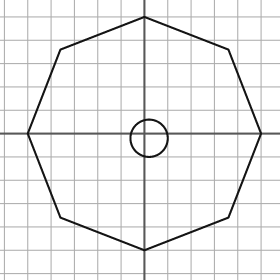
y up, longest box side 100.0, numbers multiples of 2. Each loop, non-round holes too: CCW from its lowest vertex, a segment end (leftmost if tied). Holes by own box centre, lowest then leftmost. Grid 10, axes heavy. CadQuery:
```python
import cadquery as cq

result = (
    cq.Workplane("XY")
    .moveTo(0.0, -50.0)
    .lineTo(36.0, -36.0)
    .lineTo(50.0, 0.0)
    .lineTo(36.0, 36.0)
    .lineTo(0.0, 50.0)
    .lineTo(-36.0, 36.0)
    .lineTo(-50.0, 0.0)
    .lineTo(-36.0, -36.0)
    .close()
    .moveTo(2.0, -2.0)
    .circle(8.0)
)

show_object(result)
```